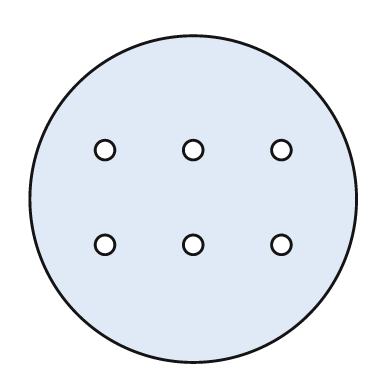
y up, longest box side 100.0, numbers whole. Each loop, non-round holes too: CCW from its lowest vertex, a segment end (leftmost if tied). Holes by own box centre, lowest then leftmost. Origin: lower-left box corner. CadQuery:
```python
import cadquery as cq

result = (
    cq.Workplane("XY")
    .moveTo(50.0, 50.0)
    .circle(50.0)
    .moveTo(23.0, 36.0)
    .circle(3.0)
    .moveTo(50.0, 36.0)
    .circle(3.0)
    .moveTo(77.0, 36.0)
    .circle(3.0)
    .moveTo(23.0, 65.0)
    .circle(3.0)
    .moveTo(50.0, 65.0)
    .circle(3.0)
    .moveTo(77.0, 65.0)
    .circle(3.0)
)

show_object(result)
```